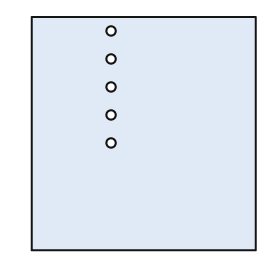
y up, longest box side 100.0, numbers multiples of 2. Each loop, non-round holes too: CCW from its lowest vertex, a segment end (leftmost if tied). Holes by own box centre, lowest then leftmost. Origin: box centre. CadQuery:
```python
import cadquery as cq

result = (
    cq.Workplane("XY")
    .moveTo(-48.0, -50.0)
    .lineTo(48.0, -50.0)
    .lineTo(48.0, 50.0)
    .lineTo(-48.0, 50.0)
    .close()
    .moveTo(-14.0, -4.0)
    .circle(2.0)
    .moveTo(-14.0, 8.0)
    .circle(2.0)
    .moveTo(-14.0, 20.0)
    .circle(2.0)
    .moveTo(-14.0, 32.0)
    .circle(2.0)
    .moveTo(-14.0, 44.0)
    .circle(2.0)
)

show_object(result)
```